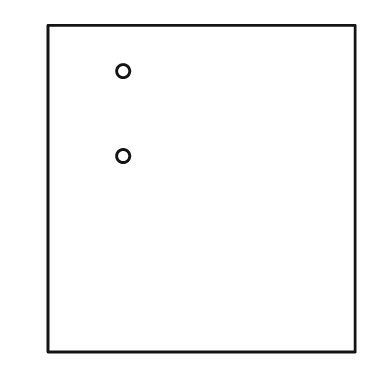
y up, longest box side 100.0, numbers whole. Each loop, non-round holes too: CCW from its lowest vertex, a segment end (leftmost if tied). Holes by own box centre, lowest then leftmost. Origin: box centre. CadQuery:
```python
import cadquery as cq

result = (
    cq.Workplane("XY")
    .moveTo(-47.0, -50.0)
    .lineTo(47.0, -50.0)
    .lineTo(47.0, 50.0)
    .lineTo(-47.0, 50.0)
    .close()
    .moveTo(-24.0, 10.0)
    .circle(2.0)
    .moveTo(-24.0, 36.0)
    .circle(2.0)
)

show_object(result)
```